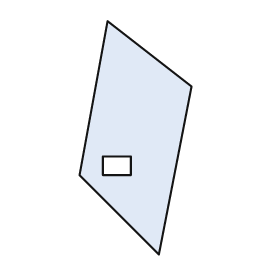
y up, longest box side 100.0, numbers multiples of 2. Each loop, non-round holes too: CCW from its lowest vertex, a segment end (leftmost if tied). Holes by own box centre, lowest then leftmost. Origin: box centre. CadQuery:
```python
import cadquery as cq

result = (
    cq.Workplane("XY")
    .moveTo(10.0, -50.0)
    .lineTo(24.0, 22.0)
    .lineTo(-12.0, 50.0)
    .lineTo(-24.0, -16.0)
    .close()
    .moveTo(-14.0, -16.0)
    .lineTo(-2.0, -16.0)
    .lineTo(-2.0, -8.0)
    .lineTo(-14.0, -8.0)
    .close()
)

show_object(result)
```